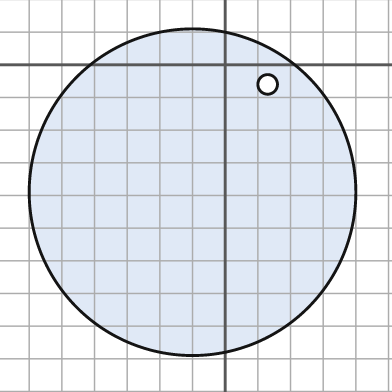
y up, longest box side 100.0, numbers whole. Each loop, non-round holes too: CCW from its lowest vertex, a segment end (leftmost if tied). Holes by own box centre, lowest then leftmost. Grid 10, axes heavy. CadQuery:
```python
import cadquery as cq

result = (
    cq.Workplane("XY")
    .moveTo(-10.0, -39.0)
    .circle(50.0)
    .moveTo(13.0, -6.0)
    .circle(3.0)
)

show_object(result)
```